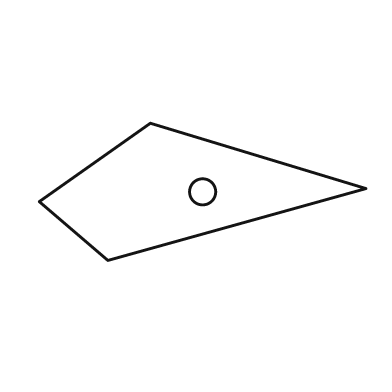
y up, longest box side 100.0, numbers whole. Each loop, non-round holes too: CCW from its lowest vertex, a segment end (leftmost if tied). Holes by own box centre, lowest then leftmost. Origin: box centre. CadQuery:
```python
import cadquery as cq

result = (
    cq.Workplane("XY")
    .moveTo(-29.0, -21.0)
    .lineTo(50.0, 1.0)
    .lineTo(-16.0, 21.0)
    .lineTo(-50.0, -3.0)
    .close()
    .moveTo(0.0, 0.0)
    .circle(4.0)
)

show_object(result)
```